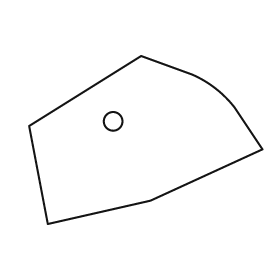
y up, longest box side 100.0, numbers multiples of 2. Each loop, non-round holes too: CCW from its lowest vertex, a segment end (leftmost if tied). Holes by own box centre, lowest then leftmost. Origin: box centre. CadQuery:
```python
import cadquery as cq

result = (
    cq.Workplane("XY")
    .moveTo(-42.0, -36.0)
    .lineTo(2.0, -26.0)
    .lineTo(50.0, -4.0)
    .lineTo(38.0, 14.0)
    .threePointArc((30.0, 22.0), (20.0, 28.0))
    .lineTo(-2.0, 36.0)
    .lineTo(-50.0, 6.0)
    .close()
    .moveTo(-14.0, 8.0)
    .circle(4.0)
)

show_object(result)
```